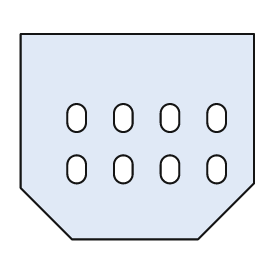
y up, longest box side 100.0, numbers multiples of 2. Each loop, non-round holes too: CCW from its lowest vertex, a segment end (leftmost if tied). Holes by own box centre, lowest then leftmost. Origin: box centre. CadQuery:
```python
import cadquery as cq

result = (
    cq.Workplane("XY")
    .moveTo(-28.0, -44.0)
    .lineTo(26.0, -44.0)
    .lineTo(50.0, -20.0)
    .lineTo(50.0, 44.0)
    .lineTo(-50.0, 44.0)
    .lineTo(-50.0, -22.0)
    .close()
    .moveTo(-30.0, -16.0)
    .threePointArc((-26.0, -20.0), (-22.0, -16.0))
    .lineTo(-22.0, -12.0)
    .threePointArc((-26.0, -8.0), (-30.0, -12.0))
    .close()
    .moveTo(-10.0, -16.0)
    .threePointArc((-6.0, -20.0), (-2.0, -16.0))
    .lineTo(-2.0, -12.0)
    .threePointArc((-6.0, -8.0), (-10.0, -12.0))
    .close()
    .moveTo(10.0, -16.0)
    .threePointArc((14.0, -20.0), (18.0, -16.0))
    .lineTo(18.0, -12.0)
    .threePointArc((14.0, -8.0), (10.0, -12.0))
    .close()
    .moveTo(30.0, -16.0)
    .threePointArc((34.0, -20.0), (38.0, -16.0))
    .lineTo(38.0, -12.0)
    .threePointArc((34.0, -8.0), (30.0, -12.0))
    .close()
    .moveTo(-30.0, 6.0)
    .threePointArc((-26.0, 2.0), (-22.0, 6.0))
    .lineTo(-22.0, 10.0)
    .threePointArc((-26.0, 14.0), (-30.0, 10.0))
    .close()
    .moveTo(-10.0, 6.0)
    .threePointArc((-6.0, 2.0), (-2.0, 6.0))
    .lineTo(-2.0, 10.0)
    .threePointArc((-6.0, 14.0), (-10.0, 10.0))
    .close()
    .moveTo(10.0, 6.0)
    .threePointArc((14.0, 2.0), (18.0, 6.0))
    .lineTo(18.0, 10.0)
    .threePointArc((14.0, 14.0), (10.0, 10.0))
    .close()
    .moveTo(30.0, 6.0)
    .threePointArc((34.0, 2.0), (38.0, 6.0))
    .lineTo(38.0, 10.0)
    .threePointArc((34.0, 14.0), (30.0, 10.0))
    .close()
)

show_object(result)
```